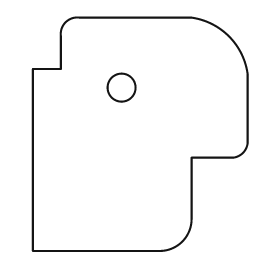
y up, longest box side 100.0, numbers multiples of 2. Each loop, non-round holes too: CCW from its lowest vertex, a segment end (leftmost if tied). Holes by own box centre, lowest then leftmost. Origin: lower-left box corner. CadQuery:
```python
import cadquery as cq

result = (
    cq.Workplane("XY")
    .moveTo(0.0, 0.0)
    .lineTo(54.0, 0.0)
    .threePointArc((64.0, 4.0), (68.0, 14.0))
    .lineTo(68.0, 40.0)
    .lineTo(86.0, 40.0)
    .threePointArc((90.0, 42.0), (92.0, 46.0))
    .lineTo(92.0, 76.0)
    .threePointArc((84.0, 92.0), (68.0, 100.0))
    .lineTo(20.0, 100.0)
    .threePointArc((14.0, 98.0), (12.0, 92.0))
    .lineTo(12.0, 78.0)
    .lineTo(0.0, 78.0)
    .close()
    .moveTo(38.0, 70.0)
    .circle(6.0)
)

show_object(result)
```